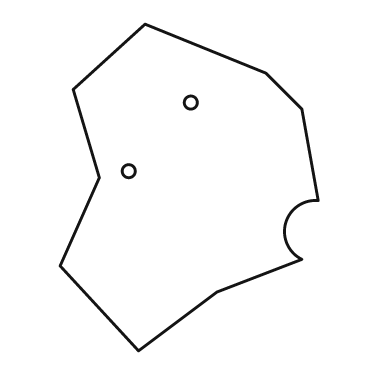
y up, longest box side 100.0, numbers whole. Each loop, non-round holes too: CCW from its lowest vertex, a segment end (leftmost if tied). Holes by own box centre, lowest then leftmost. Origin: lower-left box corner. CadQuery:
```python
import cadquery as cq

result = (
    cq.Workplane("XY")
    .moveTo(24.0, 0.0)
    .lineTo(48.0, 18.0)
    .lineTo(74.0, 28.0)
    .threePointArc((69.0, 39.0), (79.0, 46.0))
    .lineTo(74.0, 74.0)
    .lineTo(63.0, 85.0)
    .lineTo(26.0, 100.0)
    .lineTo(4.0, 80.0)
    .lineTo(12.0, 53.0)
    .lineTo(0.0, 26.0)
    .close()
    .moveTo(21.0, 55.0)
    .circle(2.0)
    .moveTo(40.0, 76.0)
    .circle(2.0)
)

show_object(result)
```